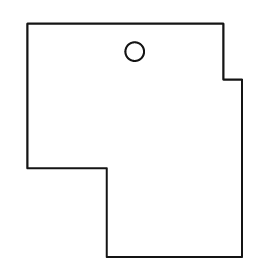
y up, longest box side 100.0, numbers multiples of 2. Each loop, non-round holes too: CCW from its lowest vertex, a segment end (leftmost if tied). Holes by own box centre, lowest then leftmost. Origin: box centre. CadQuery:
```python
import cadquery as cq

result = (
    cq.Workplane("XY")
    .moveTo(-12.0, -50.0)
    .lineTo(46.0, -50.0)
    .lineTo(46.0, 26.0)
    .lineTo(38.0, 26.0)
    .lineTo(38.0, 50.0)
    .lineTo(-46.0, 50.0)
    .lineTo(-46.0, -12.0)
    .lineTo(-12.0, -12.0)
    .close()
    .moveTo(0.0, 38.0)
    .circle(4.0)
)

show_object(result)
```